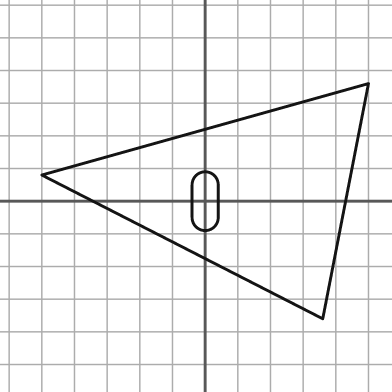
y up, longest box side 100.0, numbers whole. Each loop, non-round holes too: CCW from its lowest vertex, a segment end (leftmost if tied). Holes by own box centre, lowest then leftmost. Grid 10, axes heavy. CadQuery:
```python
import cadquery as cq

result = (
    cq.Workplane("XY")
    .moveTo(36.0, -36.0)
    .lineTo(50.0, 36.0)
    .lineTo(-50.0, 8.0)
    .close()
    .moveTo(-4.0, -5.0)
    .threePointArc((0.0, -9.0), (4.0, -5.0))
    .lineTo(4.0, 5.0)
    .threePointArc((0.0, 9.0), (-4.0, 5.0))
    .close()
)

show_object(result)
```